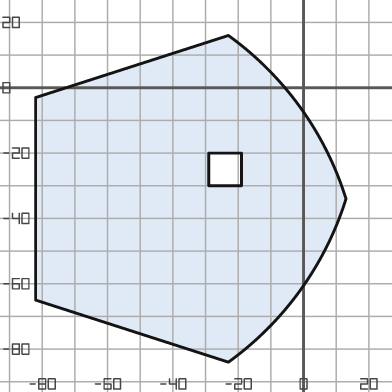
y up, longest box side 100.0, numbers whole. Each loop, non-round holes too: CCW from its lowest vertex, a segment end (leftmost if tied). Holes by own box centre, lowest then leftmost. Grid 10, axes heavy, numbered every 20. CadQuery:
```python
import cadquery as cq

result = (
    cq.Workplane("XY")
    .moveTo(-23.0, -84.0)
    .threePointArc((-1.0, -62.0), (13.0, -34.0))
    .threePointArc((-1.0, -6.0), (-23.0, 16.0))
    .lineTo(-82.0, -3.0)
    .lineTo(-82.0, -65.0)
    .close()
    .moveTo(-29.0, -30.0)
    .lineTo(-19.0, -30.0)
    .lineTo(-19.0, -20.0)
    .lineTo(-29.0, -20.0)
    .close()
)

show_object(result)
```